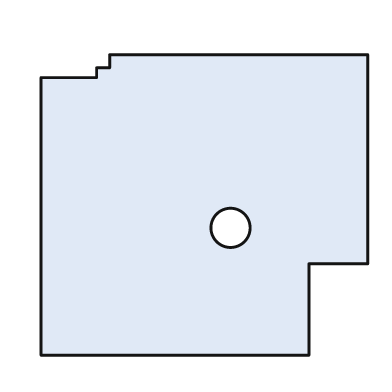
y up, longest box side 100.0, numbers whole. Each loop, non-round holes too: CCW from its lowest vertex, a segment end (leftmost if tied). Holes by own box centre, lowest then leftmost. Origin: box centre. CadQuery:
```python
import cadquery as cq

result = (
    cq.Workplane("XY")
    .moveTo(-50.0, -46.0)
    .lineTo(32.0, -46.0)
    .lineTo(32.0, -18.0)
    .lineTo(50.0, -18.0)
    .lineTo(50.0, 46.0)
    .lineTo(-29.0, 46.0)
    .lineTo(-29.0, 42.0)
    .lineTo(-33.0, 42.0)
    .lineTo(-33.0, 39.0)
    .lineTo(-50.0, 39.0)
    .close()
    .moveTo(8.0, -7.0)
    .circle(6.0)
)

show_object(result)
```